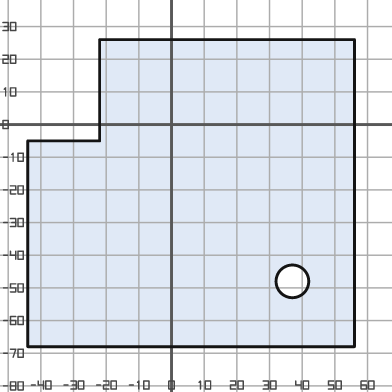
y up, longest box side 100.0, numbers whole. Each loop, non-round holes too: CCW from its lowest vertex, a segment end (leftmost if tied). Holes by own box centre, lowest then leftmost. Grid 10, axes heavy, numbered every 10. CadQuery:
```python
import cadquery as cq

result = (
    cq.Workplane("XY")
    .moveTo(-44.0, -68.0)
    .lineTo(56.0, -68.0)
    .lineTo(56.0, 26.0)
    .lineTo(-22.0, 26.0)
    .lineTo(-22.0, -5.0)
    .lineTo(-44.0, -5.0)
    .close()
    .moveTo(37.0, -48.0)
    .circle(5.0)
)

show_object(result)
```